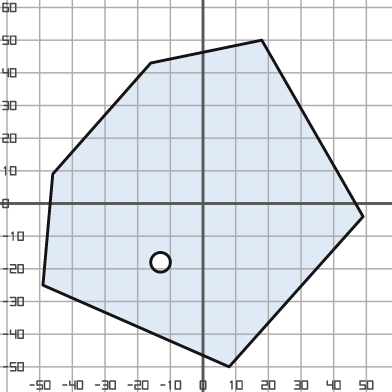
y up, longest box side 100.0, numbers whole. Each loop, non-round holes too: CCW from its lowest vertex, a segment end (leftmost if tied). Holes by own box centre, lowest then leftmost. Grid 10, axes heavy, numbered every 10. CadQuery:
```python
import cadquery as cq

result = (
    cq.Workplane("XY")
    .moveTo(8.0, -50.0)
    .lineTo(49.0, -4.0)
    .lineTo(18.0, 50.0)
    .lineTo(-16.0, 43.0)
    .lineTo(-46.0, 9.0)
    .lineTo(-49.0, -25.0)
    .close()
    .moveTo(-13.0, -18.0)
    .circle(3.0)
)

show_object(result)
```